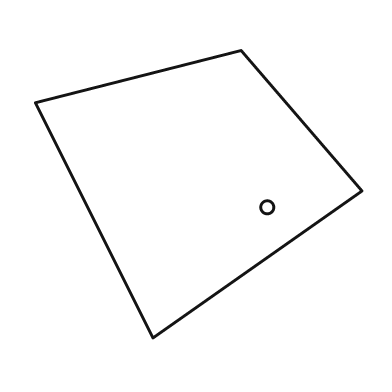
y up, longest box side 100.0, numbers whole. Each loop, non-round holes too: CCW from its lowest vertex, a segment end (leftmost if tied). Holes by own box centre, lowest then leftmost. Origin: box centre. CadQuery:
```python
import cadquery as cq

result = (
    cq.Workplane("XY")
    .moveTo(-14.0, -44.0)
    .lineTo(50.0, 1.0)
    .lineTo(13.0, 44.0)
    .lineTo(-50.0, 28.0)
    .close()
    .moveTo(21.0, -4.0)
    .circle(2.0)
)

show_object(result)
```